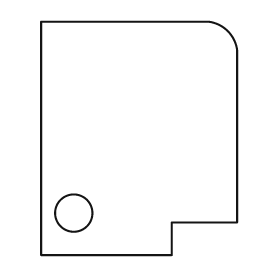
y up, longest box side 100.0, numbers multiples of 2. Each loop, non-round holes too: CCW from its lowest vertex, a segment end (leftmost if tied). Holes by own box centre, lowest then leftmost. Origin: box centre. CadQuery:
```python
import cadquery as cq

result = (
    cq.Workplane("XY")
    .moveTo(-42.0, -50.0)
    .lineTo(14.0, -50.0)
    .lineTo(14.0, -36.0)
    .lineTo(42.0, -36.0)
    .lineTo(42.0, 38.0)
    .threePointArc((38.0, 46.0), (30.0, 50.0))
    .lineTo(-42.0, 50.0)
    .close()
    .moveTo(-28.0, -32.0)
    .circle(8.0)
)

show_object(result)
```